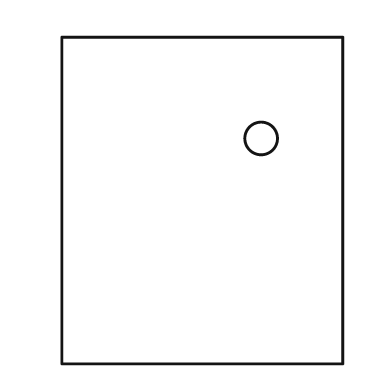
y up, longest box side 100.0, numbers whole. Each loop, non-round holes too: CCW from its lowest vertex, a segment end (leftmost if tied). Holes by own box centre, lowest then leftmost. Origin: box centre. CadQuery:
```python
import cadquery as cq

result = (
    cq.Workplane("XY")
    .moveTo(-43.0, -50.0)
    .lineTo(43.0, -50.0)
    .lineTo(43.0, 50.0)
    .lineTo(-43.0, 50.0)
    .close()
    .moveTo(18.0, 19.0)
    .circle(5.0)
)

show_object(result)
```